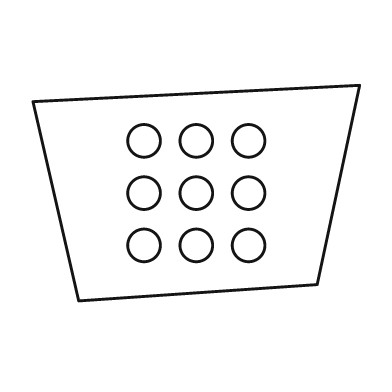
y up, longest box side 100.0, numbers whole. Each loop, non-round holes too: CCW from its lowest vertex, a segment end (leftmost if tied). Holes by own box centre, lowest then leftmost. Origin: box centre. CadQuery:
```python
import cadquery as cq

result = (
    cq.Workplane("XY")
    .moveTo(-36.0, -33.0)
    .lineTo(37.0, -28.0)
    .lineTo(50.0, 33.0)
    .lineTo(-50.0, 28.0)
    .close()
    .moveTo(-16.0, -16.0)
    .circle(5.0)
    .moveTo(0.0, -16.0)
    .circle(5.0)
    .moveTo(16.0, -16.0)
    .circle(5.0)
    .moveTo(-16.0, 0.0)
    .circle(5.0)
    .moveTo(0.0, 0.0)
    .circle(5.0)
    .moveTo(16.0, 0.0)
    .circle(5.0)
    .moveTo(-16.0, 16.0)
    .circle(5.0)
    .moveTo(0.0, 16.0)
    .circle(5.0)
    .moveTo(16.0, 16.0)
    .circle(5.0)
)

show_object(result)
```